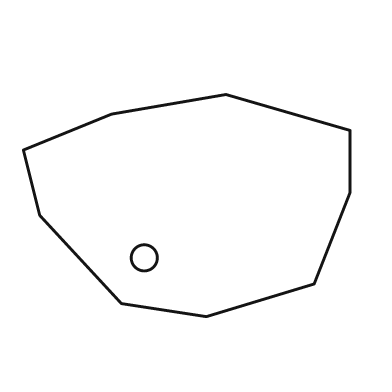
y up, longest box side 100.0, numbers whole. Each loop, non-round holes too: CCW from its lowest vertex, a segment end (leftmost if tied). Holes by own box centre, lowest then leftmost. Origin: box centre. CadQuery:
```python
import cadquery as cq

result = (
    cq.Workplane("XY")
    .moveTo(6.0, -34.0)
    .lineTo(39.0, -24.0)
    .lineTo(50.0, 4.0)
    .lineTo(50.0, 23.0)
    .lineTo(12.0, 34.0)
    .lineTo(-23.0, 28.0)
    .lineTo(-50.0, 17.0)
    .lineTo(-45.0, -3.0)
    .lineTo(-20.0, -30.0)
    .close()
    .moveTo(-13.0, -16.0)
    .circle(4.0)
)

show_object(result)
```